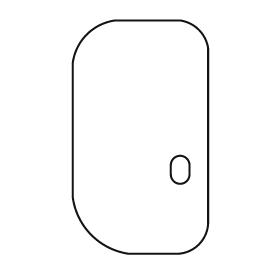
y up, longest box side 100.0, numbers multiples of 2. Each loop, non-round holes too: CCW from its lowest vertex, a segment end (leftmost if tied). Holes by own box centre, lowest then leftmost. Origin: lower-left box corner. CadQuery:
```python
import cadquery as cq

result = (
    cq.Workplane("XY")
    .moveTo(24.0, 0.0)
    .lineTo(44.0, 0.0)
    .threePointArc((54.0, 4.0), (58.0, 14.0))
    .lineTo(58.0, 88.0)
    .threePointArc((54.0, 96.0), (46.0, 100.0))
    .lineTo(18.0, 100.0)
    .threePointArc((6.0, 94.0), (0.0, 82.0))
    .lineTo(0.0, 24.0)
    .threePointArc((8.0, 8.0), (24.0, 0.0))
    .close()
    .moveTo(42.0, 34.0)
    .threePointArc((46.0, 30.0), (50.0, 34.0))
    .lineTo(50.0, 38.0)
    .threePointArc((46.0, 42.0), (42.0, 38.0))
    .close()
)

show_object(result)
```